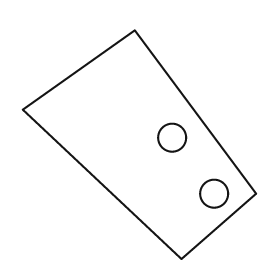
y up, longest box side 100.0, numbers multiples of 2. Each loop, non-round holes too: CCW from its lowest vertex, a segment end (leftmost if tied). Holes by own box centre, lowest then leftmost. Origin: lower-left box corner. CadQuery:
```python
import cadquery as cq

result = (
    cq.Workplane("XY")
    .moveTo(68.0, 0.0)
    .lineTo(100.0, 28.0)
    .lineTo(48.0, 98.0)
    .lineTo(0.0, 64.0)
    .close()
    .moveTo(82.0, 28.0)
    .circle(6.0)
    .moveTo(64.0, 52.0)
    .circle(6.0)
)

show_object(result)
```